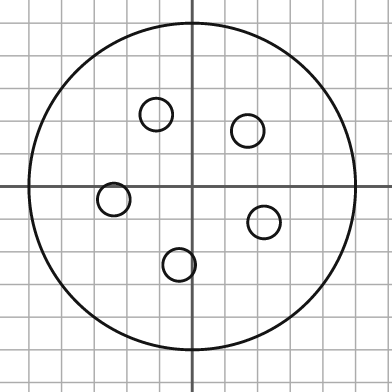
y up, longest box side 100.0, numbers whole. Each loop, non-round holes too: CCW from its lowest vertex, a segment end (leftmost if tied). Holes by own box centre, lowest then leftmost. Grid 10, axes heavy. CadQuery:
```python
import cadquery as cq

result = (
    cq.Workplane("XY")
    .moveTo(0.0, 0.0)
    .circle(50.0)
    .moveTo(-4.0, -24.0)
    .circle(5.0)
    .moveTo(22.0, -11.0)
    .circle(5.0)
    .moveTo(-24.0, -4.0)
    .circle(5.0)
    .moveTo(17.0, 17.0)
    .circle(5.0)
    .moveTo(-11.0, 22.0)
    .circle(5.0)
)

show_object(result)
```